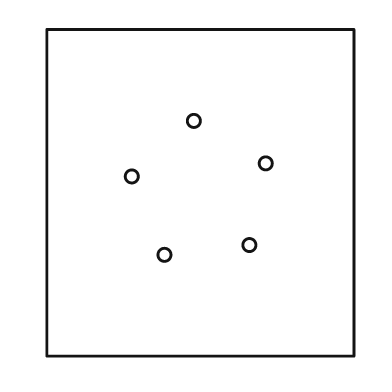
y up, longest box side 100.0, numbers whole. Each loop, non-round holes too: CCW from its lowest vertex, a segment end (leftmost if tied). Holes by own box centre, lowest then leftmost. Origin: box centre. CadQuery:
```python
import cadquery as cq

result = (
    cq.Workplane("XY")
    .moveTo(-47.0, -50.0)
    .lineTo(47.0, -50.0)
    .lineTo(47.0, 50.0)
    .lineTo(-47.0, 50.0)
    .close()
    .moveTo(-11.0, -19.0)
    .circle(2.0)
    .moveTo(15.0, -16.0)
    .circle(2.0)
    .moveTo(-21.0, 5.0)
    .circle(2.0)
    .moveTo(20.0, 9.0)
    .circle(2.0)
    .moveTo(-2.0, 22.0)
    .circle(2.0)
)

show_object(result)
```